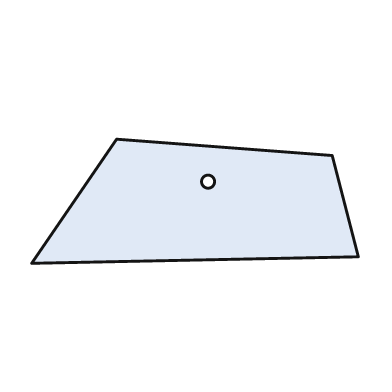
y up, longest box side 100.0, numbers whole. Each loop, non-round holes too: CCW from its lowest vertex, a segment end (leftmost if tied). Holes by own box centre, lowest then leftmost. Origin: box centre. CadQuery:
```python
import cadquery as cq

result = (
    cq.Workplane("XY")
    .moveTo(-50.0, -19.0)
    .lineTo(50.0, -17.0)
    .lineTo(42.0, 14.0)
    .lineTo(-24.0, 19.0)
    .close()
    .moveTo(4.0, 6.0)
    .circle(2.0)
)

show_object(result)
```